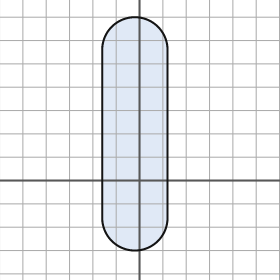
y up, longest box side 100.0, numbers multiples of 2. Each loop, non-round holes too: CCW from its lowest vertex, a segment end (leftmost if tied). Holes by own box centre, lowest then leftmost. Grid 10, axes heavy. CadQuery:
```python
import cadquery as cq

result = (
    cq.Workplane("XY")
    .moveTo(-16.0, -16.0)
    .threePointArc((-2.0, -30.0), (12.0, -16.0))
    .lineTo(12.0, 56.0)
    .threePointArc((-2.0, 70.0), (-16.0, 56.0))
    .close()
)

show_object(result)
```